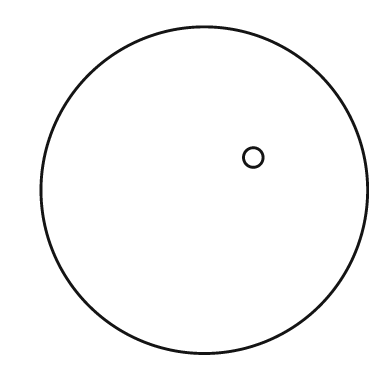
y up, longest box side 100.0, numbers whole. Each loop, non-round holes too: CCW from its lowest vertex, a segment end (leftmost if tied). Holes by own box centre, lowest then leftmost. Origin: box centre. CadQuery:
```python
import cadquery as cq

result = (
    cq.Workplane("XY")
    .moveTo(0.0, 0.0)
    .circle(50.0)
    .moveTo(15.0, 10.0)
    .circle(3.0)
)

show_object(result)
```